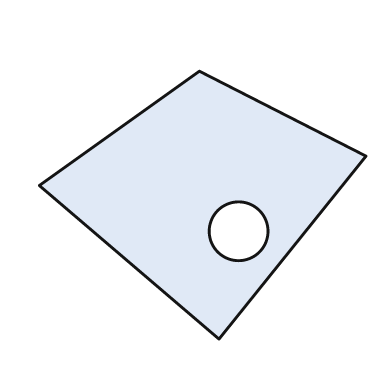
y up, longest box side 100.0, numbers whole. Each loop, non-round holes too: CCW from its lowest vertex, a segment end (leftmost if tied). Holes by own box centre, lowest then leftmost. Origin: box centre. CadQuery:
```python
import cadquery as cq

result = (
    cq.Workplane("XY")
    .moveTo(5.0, -41.0)
    .lineTo(50.0, 15.0)
    .lineTo(-1.0, 41.0)
    .lineTo(-50.0, 6.0)
    .close()
    .moveTo(11.0, -8.0)
    .circle(9.0)
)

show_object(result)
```